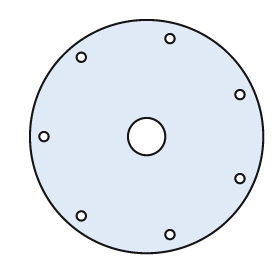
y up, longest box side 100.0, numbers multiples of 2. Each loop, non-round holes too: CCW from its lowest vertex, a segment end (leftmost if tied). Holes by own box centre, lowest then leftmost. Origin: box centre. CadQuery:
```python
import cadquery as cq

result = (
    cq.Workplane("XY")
    .moveTo(0.0, 0.0)
    .circle(50.0)
    .moveTo(10.0, -42.0)
    .circle(2.0)
    .moveTo(-28.0, -34.0)
    .circle(2.0)
    .moveTo(40.0, -18.0)
    .circle(2.0)
    .moveTo(-44.0, 0.0)
    .circle(2.0)
    .moveTo(0.0, 0.0)
    .circle(8.0)
    .moveTo(40.0, 18.0)
    .circle(2.0)
    .moveTo(-28.0, 34.0)
    .circle(2.0)
    .moveTo(10.0, 42.0)
    .circle(2.0)
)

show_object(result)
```